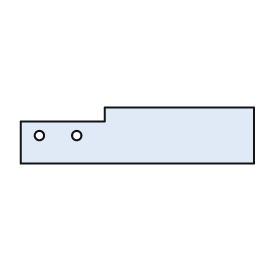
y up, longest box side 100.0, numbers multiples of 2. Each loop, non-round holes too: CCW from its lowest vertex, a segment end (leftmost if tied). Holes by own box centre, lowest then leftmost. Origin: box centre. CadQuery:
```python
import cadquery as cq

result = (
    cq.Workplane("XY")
    .moveTo(-50.0, -12.0)
    .lineTo(50.0, -12.0)
    .lineTo(50.0, 12.0)
    .lineTo(-14.0, 12.0)
    .lineTo(-14.0, 6.0)
    .lineTo(-50.0, 6.0)
    .close()
    .moveTo(-42.0, 0.0)
    .circle(2.0)
    .moveTo(-26.0, 0.0)
    .circle(2.0)
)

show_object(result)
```